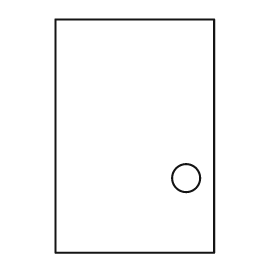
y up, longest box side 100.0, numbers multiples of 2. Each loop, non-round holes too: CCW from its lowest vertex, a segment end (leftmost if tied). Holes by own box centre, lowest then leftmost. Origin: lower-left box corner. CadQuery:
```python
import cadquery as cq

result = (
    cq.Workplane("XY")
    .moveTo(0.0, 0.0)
    .lineTo(68.0, 0.0)
    .lineTo(68.0, 100.0)
    .lineTo(0.0, 100.0)
    .close()
    .moveTo(56.0, 32.0)
    .circle(6.0)
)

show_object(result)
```